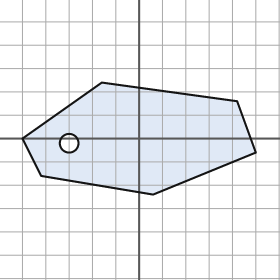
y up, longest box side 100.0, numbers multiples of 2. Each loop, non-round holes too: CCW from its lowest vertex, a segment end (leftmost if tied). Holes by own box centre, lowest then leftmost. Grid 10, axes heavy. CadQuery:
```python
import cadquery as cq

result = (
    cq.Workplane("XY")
    .moveTo(6.0, -24.0)
    .lineTo(50.0, -6.0)
    .lineTo(42.0, 16.0)
    .lineTo(-16.0, 24.0)
    .lineTo(-50.0, 0.0)
    .lineTo(-42.0, -16.0)
    .close()
    .moveTo(-30.0, -2.0)
    .circle(4.0)
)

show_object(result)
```